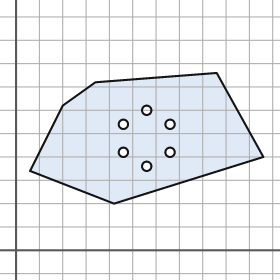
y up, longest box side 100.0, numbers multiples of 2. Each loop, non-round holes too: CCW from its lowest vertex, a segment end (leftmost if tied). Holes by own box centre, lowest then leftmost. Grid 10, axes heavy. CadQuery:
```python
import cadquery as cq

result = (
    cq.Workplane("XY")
    .moveTo(42.0, 20.0)
    .lineTo(106.0, 40.0)
    .lineTo(86.0, 76.0)
    .lineTo(34.0, 72.0)
    .lineTo(20.0, 62.0)
    .lineTo(6.0, 34.0)
    .close()
    .moveTo(56.0, 36.0)
    .circle(2.0)
    .moveTo(46.0, 42.0)
    .circle(2.0)
    .moveTo(66.0, 42.0)
    .circle(2.0)
    .moveTo(46.0, 54.0)
    .circle(2.0)
    .moveTo(66.0, 54.0)
    .circle(2.0)
    .moveTo(56.0, 60.0)
    .circle(2.0)
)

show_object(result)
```